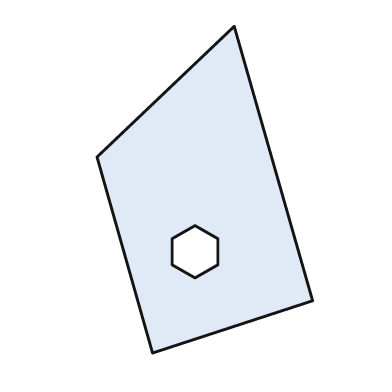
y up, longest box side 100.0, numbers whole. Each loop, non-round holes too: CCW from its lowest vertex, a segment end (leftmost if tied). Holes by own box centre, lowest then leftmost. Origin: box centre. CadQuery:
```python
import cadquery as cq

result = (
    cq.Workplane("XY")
    .moveTo(-16.0, -50.0)
    .lineTo(33.0, -34.0)
    .lineTo(9.0, 50.0)
    .lineTo(-33.0, 10.0)
    .close()
    .moveTo(-3.0, -27.0)
    .lineTo(4.0, -23.0)
    .lineTo(4.0, -15.0)
    .lineTo(-3.0, -11.0)
    .lineTo(-10.0, -15.0)
    .lineTo(-10.0, -23.0)
    .close()
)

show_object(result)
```